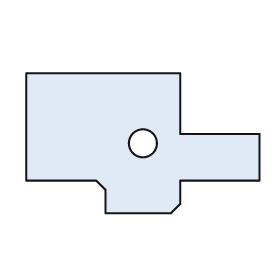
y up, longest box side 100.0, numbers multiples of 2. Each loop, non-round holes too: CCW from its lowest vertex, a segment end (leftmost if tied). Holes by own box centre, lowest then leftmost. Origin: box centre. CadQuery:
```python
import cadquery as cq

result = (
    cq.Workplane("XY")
    .moveTo(-16.0, -30.0)
    .lineTo(12.0, -30.0)
    .lineTo(16.0, -26.0)
    .lineTo(16.0, -16.0)
    .lineTo(50.0, -16.0)
    .lineTo(50.0, 4.0)
    .lineTo(16.0, 4.0)
    .lineTo(16.0, 30.0)
    .lineTo(-50.0, 30.0)
    .lineTo(-50.0, -16.0)
    .lineTo(-20.0, -16.0)
    .lineTo(-16.0, -20.0)
    .close()
    .moveTo(0.0, 0.0)
    .circle(6.0)
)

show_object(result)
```